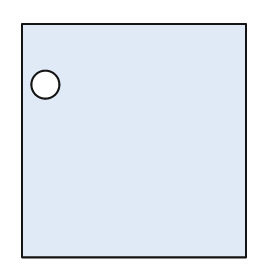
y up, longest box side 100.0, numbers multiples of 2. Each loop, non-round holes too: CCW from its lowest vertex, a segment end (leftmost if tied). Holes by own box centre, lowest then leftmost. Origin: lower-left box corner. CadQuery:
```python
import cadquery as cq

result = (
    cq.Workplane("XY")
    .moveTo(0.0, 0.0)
    .lineTo(96.0, 0.0)
    .lineTo(96.0, 100.0)
    .lineTo(0.0, 100.0)
    .close()
    .moveTo(10.0, 74.0)
    .circle(6.0)
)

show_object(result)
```